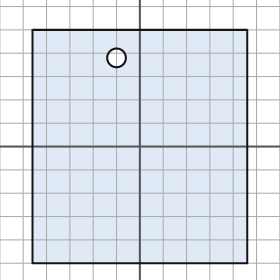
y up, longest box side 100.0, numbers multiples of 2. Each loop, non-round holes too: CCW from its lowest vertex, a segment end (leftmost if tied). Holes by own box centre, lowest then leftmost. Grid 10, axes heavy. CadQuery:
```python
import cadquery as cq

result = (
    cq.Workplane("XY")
    .moveTo(-46.0, -50.0)
    .lineTo(46.0, -50.0)
    .lineTo(46.0, 50.0)
    .lineTo(-46.0, 50.0)
    .close()
    .moveTo(-10.0, 38.0)
    .circle(4.0)
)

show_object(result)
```